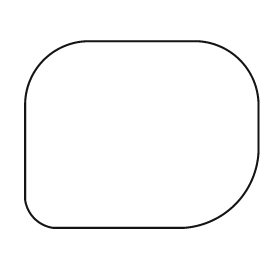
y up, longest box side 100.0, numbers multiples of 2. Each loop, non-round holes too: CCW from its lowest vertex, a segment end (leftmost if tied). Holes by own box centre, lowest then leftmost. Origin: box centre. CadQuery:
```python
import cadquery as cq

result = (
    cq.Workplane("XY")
    .moveTo(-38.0, -40.0)
    .lineTo(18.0, -40.0)
    .threePointArc((40.0, -30.0), (50.0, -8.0))
    .lineTo(50.0, 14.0)
    .threePointArc((42.0, 32.0), (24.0, 40.0))
    .lineTo(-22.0, 40.0)
    .threePointArc((-42.0, 32.0), (-50.0, 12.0))
    .lineTo(-50.0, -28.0)
    .threePointArc((-46.0, -36.0), (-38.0, -40.0))
    .close()
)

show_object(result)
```